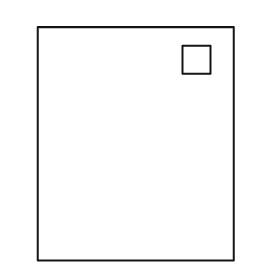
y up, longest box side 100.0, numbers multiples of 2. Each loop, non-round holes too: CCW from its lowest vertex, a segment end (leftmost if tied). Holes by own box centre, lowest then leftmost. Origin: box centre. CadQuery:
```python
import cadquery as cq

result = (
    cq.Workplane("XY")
    .moveTo(-42.0, -50.0)
    .lineTo(42.0, -50.0)
    .lineTo(42.0, 50.0)
    .lineTo(-42.0, 50.0)
    .close()
    .moveTo(20.0, 30.0)
    .lineTo(32.0, 30.0)
    .lineTo(32.0, 42.0)
    .lineTo(20.0, 42.0)
    .close()
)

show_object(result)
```